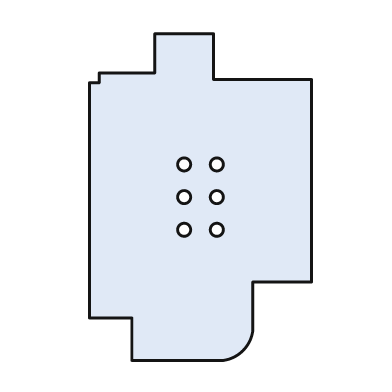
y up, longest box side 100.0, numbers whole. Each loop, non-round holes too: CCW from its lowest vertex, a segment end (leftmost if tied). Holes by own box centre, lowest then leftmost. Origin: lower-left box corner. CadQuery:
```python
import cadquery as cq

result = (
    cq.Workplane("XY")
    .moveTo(13.0, 0.0)
    .lineTo(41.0, 0.0)
    .threePointArc((47.0, 3.0), (50.0, 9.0))
    .lineTo(50.0, 24.0)
    .lineTo(68.0, 24.0)
    .lineTo(68.0, 86.0)
    .lineTo(38.0, 86.0)
    .lineTo(38.0, 100.0)
    .lineTo(20.0, 100.0)
    .lineTo(20.0, 88.0)
    .lineTo(3.0, 88.0)
    .lineTo(3.0, 85.0)
    .lineTo(0.0, 85.0)
    .lineTo(0.0, 13.0)
    .lineTo(13.0, 13.0)
    .close()
    .moveTo(29.0, 40.0)
    .circle(2.0)
    .moveTo(39.0, 40.0)
    .circle(2.0)
    .moveTo(29.0, 50.0)
    .circle(2.0)
    .moveTo(39.0, 50.0)
    .circle(2.0)
    .moveTo(29.0, 60.0)
    .circle(2.0)
    .moveTo(39.0, 60.0)
    .circle(2.0)
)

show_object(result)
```